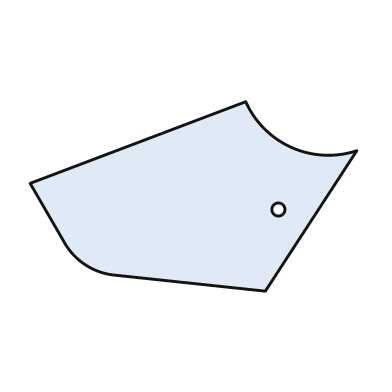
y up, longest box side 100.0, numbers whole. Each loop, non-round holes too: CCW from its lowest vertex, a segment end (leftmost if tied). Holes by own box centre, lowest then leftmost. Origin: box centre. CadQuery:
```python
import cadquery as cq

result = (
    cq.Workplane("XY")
    .moveTo(22.0, -29.0)
    .lineTo(50.0, 14.0)
    .threePointArc((30.0, 15.0), (16.0, 29.0))
    .lineTo(-50.0, 4.0)
    .lineTo(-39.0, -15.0)
    .threePointArc((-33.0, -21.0), (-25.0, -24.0))
    .close()
    .moveTo(26.0, -4.0)
    .circle(2.0)
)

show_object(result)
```